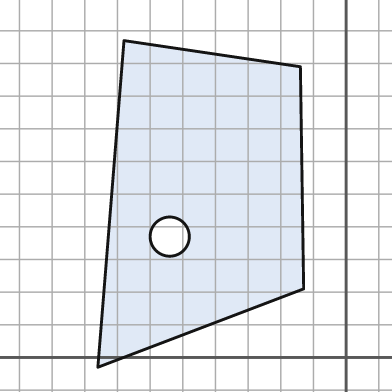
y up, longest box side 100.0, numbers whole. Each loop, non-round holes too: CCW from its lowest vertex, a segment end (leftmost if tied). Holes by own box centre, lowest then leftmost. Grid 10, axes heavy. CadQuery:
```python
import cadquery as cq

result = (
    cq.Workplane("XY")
    .moveTo(-76.0, -3.0)
    .lineTo(-13.0, 21.0)
    .lineTo(-14.0, 89.0)
    .lineTo(-68.0, 97.0)
    .close()
    .moveTo(-54.0, 37.0)
    .circle(6.0)
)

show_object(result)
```